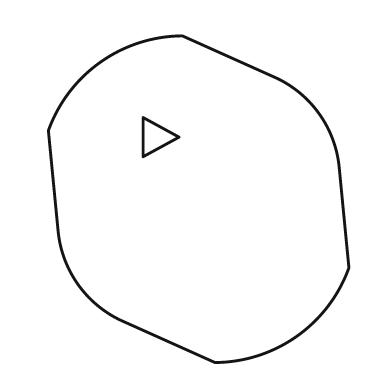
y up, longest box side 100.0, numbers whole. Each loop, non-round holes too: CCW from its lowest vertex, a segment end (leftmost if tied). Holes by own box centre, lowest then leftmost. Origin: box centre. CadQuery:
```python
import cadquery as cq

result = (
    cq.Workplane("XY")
    .moveTo(5.0, -50.0)
    .threePointArc((30.0, -42.0), (46.0, -21.0))
    .lineTo(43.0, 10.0)
    .threePointArc((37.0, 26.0), (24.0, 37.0))
    .lineTo(-5.0, 50.0)
    .threePointArc((-30.0, 42.0), (-46.0, 21.0))
    .lineTo(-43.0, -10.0)
    .threePointArc((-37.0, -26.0), (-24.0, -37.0))
    .close()
    .moveTo(-17.0, 13.0)
    .lineTo(-6.0, 19.0)
    .lineTo(-17.0, 25.0)
    .close()
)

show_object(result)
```